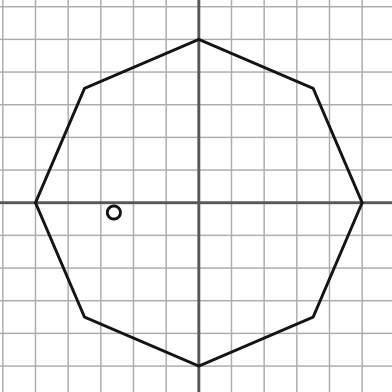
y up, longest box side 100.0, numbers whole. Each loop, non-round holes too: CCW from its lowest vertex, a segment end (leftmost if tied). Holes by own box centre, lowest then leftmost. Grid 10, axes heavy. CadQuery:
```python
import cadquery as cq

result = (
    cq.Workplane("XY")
    .moveTo(0.0, -50.0)
    .lineTo(35.0, -35.0)
    .lineTo(50.0, 0.0)
    .lineTo(35.0, 35.0)
    .lineTo(0.0, 50.0)
    .lineTo(-35.0, 35.0)
    .lineTo(-50.0, 0.0)
    .lineTo(-35.0, -35.0)
    .close()
    .moveTo(-26.0, -3.0)
    .circle(2.0)
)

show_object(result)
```